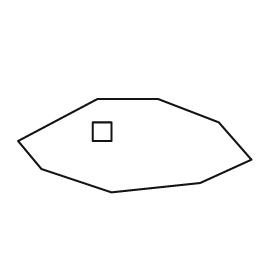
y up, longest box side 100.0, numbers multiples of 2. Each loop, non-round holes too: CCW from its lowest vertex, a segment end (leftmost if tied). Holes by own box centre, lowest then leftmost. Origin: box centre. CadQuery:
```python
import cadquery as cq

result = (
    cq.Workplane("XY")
    .moveTo(-10.0, -20.0)
    .lineTo(28.0, -16.0)
    .lineTo(50.0, -6.0)
    .lineTo(36.0, 10.0)
    .lineTo(10.0, 20.0)
    .lineTo(-16.0, 20.0)
    .lineTo(-50.0, 2.0)
    .lineTo(-40.0, -10.0)
    .close()
    .moveTo(-18.0, 2.0)
    .lineTo(-10.0, 2.0)
    .lineTo(-10.0, 10.0)
    .lineTo(-18.0, 10.0)
    .close()
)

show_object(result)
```